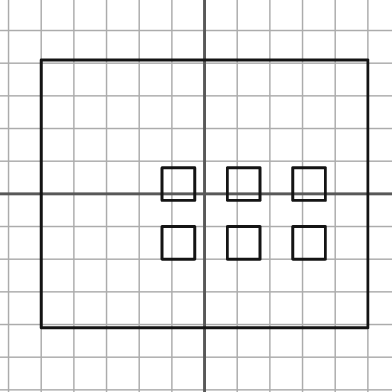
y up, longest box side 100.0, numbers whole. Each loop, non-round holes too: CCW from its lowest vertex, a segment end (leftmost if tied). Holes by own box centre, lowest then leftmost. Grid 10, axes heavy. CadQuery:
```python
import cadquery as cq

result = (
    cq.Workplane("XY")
    .moveTo(-50.0, -41.0)
    .lineTo(50.0, -41.0)
    .lineTo(50.0, 41.0)
    .lineTo(-50.0, 41.0)
    .close()
    .moveTo(-13.0, -20.0)
    .lineTo(-3.0, -20.0)
    .lineTo(-3.0, -10.0)
    .lineTo(-13.0, -10.0)
    .close()
    .moveTo(7.0, -20.0)
    .lineTo(17.0, -20.0)
    .lineTo(17.0, -10.0)
    .lineTo(7.0, -10.0)
    .close()
    .moveTo(27.0, -20.0)
    .lineTo(37.0, -20.0)
    .lineTo(37.0, -10.0)
    .lineTo(27.0, -10.0)
    .close()
    .moveTo(-13.0, -2.0)
    .lineTo(-3.0, -2.0)
    .lineTo(-3.0, 8.0)
    .lineTo(-13.0, 8.0)
    .close()
    .moveTo(7.0, -2.0)
    .lineTo(17.0, -2.0)
    .lineTo(17.0, 8.0)
    .lineTo(7.0, 8.0)
    .close()
    .moveTo(27.0, -2.0)
    .lineTo(37.0, -2.0)
    .lineTo(37.0, 8.0)
    .lineTo(27.0, 8.0)
    .close()
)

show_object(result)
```